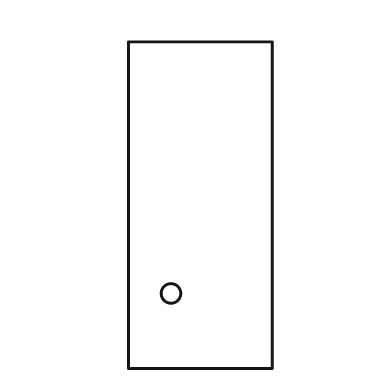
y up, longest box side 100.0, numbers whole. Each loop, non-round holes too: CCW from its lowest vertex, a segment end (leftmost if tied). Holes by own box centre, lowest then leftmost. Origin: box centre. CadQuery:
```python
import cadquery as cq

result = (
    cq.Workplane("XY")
    .moveTo(-22.0, -50.0)
    .lineTo(22.0, -50.0)
    .lineTo(22.0, 50.0)
    .lineTo(-22.0, 50.0)
    .close()
    .moveTo(-9.0, -27.0)
    .circle(3.0)
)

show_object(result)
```